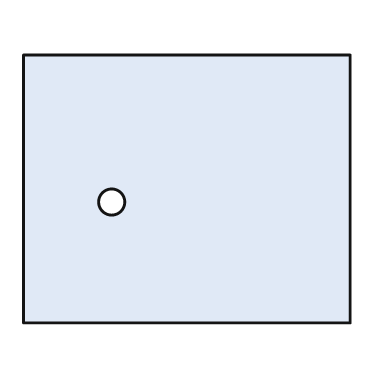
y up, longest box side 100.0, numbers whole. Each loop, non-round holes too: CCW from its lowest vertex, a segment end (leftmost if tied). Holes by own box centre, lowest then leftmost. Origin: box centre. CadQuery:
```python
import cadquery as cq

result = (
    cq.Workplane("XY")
    .moveTo(-50.0, -41.0)
    .lineTo(50.0, -41.0)
    .lineTo(50.0, 41.0)
    .lineTo(-50.0, 41.0)
    .close()
    .moveTo(-23.0, -4.0)
    .circle(4.0)
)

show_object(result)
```